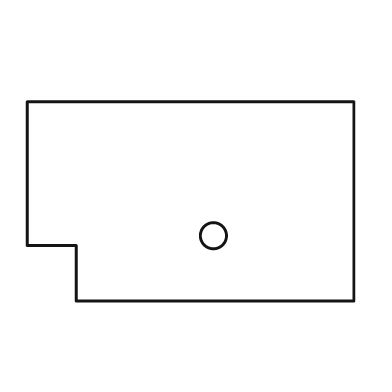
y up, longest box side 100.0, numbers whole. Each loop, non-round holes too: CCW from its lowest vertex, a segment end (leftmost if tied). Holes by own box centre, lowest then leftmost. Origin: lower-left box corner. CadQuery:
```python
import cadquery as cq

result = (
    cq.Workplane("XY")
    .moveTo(15.0, 0.0)
    .lineTo(100.0, 0.0)
    .lineTo(100.0, 61.0)
    .lineTo(0.0, 61.0)
    .lineTo(0.0, 17.0)
    .lineTo(15.0, 17.0)
    .close()
    .moveTo(57.0, 20.0)
    .circle(4.0)
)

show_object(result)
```